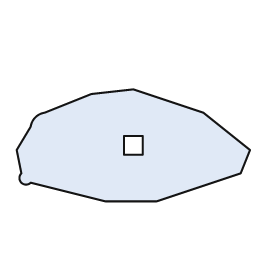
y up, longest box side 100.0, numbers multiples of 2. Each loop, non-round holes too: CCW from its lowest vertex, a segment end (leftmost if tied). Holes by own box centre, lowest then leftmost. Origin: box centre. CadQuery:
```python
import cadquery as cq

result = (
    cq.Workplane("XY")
    .moveTo(-12.0, -24.0)
    .lineTo(10.0, -24.0)
    .lineTo(46.0, -12.0)
    .lineTo(50.0, -2.0)
    .lineTo(30.0, 14.0)
    .lineTo(0.0, 24.0)
    .lineTo(-18.0, 22.0)
    .lineTo(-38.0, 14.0)
    .threePointArc((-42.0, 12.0), (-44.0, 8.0))
    .lineTo(-50.0, -2.0)
    .lineTo(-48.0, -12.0)
    .threePointArc((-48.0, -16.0), (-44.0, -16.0))
    .close()
    .moveTo(-4.0, -4.0)
    .lineTo(4.0, -4.0)
    .lineTo(4.0, 4.0)
    .lineTo(-4.0, 4.0)
    .close()
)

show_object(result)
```